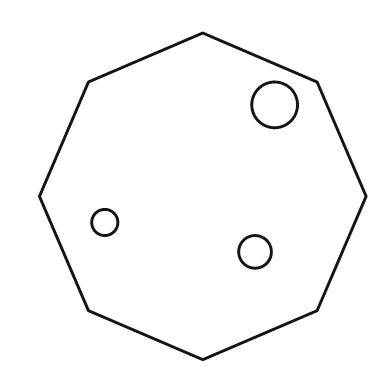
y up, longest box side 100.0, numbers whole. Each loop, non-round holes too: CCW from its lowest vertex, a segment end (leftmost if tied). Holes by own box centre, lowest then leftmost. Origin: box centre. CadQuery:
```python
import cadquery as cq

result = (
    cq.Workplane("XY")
    .moveTo(0.0, -50.0)
    .lineTo(35.0, -35.0)
    .lineTo(50.0, 0.0)
    .lineTo(35.0, 35.0)
    .lineTo(0.0, 50.0)
    .lineTo(-35.0, 35.0)
    .lineTo(-50.0, 0.0)
    .lineTo(-35.0, -35.0)
    .close()
    .moveTo(16.0, -17.0)
    .circle(5.0)
    .moveTo(-30.0, -8.0)
    .circle(4.0)
    .moveTo(22.0, 28.0)
    .circle(7.0)
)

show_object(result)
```